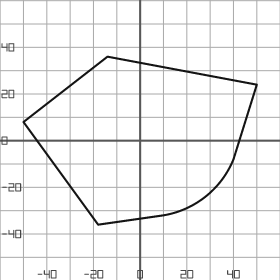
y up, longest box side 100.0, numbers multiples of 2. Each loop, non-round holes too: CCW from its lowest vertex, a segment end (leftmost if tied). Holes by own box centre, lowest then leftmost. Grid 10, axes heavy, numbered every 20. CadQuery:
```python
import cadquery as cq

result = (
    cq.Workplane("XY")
    .moveTo(-18.0, -36.0)
    .lineTo(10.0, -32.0)
    .threePointArc((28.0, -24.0), (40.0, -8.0))
    .lineTo(50.0, 24.0)
    .lineTo(-14.0, 36.0)
    .lineTo(-50.0, 8.0)
    .close()
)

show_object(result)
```